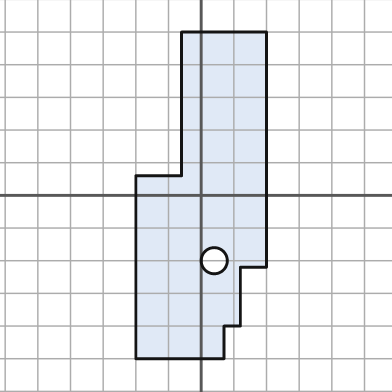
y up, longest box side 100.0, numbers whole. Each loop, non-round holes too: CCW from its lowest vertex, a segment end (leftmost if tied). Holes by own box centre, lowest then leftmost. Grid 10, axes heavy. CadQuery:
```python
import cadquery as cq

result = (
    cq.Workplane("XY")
    .moveTo(-20.0, -50.0)
    .lineTo(7.0, -50.0)
    .lineTo(7.0, -40.0)
    .lineTo(12.0, -40.0)
    .lineTo(12.0, -22.0)
    .lineTo(20.0, -22.0)
    .lineTo(20.0, 50.0)
    .lineTo(-6.0, 50.0)
    .lineTo(-6.0, 6.0)
    .lineTo(-20.0, 6.0)
    .close()
    .moveTo(4.0, -20.0)
    .circle(4.0)
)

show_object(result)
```